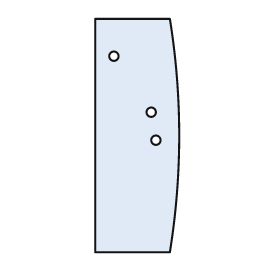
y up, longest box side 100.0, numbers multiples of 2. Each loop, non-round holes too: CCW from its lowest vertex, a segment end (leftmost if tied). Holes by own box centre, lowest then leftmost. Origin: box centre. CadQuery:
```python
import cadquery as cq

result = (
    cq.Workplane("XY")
    .moveTo(-18.0, -50.0)
    .lineTo(14.0, -50.0)
    .threePointArc((18.0, 0.0), (14.0, 50.0))
    .lineTo(-18.0, 50.0)
    .close()
    .moveTo(8.0, -2.0)
    .circle(2.0)
    .moveTo(6.0, 10.0)
    .circle(2.0)
    .moveTo(-10.0, 34.0)
    .circle(2.0)
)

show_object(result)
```